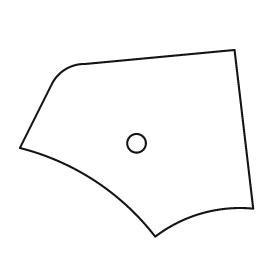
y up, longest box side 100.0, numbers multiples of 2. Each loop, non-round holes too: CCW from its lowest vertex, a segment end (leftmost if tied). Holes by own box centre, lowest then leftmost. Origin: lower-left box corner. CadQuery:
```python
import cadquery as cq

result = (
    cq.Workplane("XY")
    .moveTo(58.0, 0.0)
    .threePointArc((78.0, 10.0), (100.0, 12.0))
    .lineTo(92.0, 80.0)
    .lineTo(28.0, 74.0)
    .threePointArc((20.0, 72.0), (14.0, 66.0))
    .lineTo(0.0, 38.0)
    .threePointArc((32.0, 24.0), (58.0, 0.0))
    .close()
    .moveTo(50.0, 40.0)
    .circle(4.0)
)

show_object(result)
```